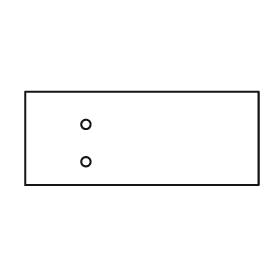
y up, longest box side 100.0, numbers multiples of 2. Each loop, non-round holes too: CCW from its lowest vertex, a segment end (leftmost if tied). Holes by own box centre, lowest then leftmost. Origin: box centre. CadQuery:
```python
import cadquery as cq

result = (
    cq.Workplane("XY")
    .moveTo(-50.0, -20.0)
    .lineTo(50.0, -20.0)
    .lineTo(50.0, 20.0)
    .lineTo(-50.0, 20.0)
    .close()
    .moveTo(-24.0, -10.0)
    .circle(2.0)
    .moveTo(-24.0, 6.0)
    .circle(2.0)
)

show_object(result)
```